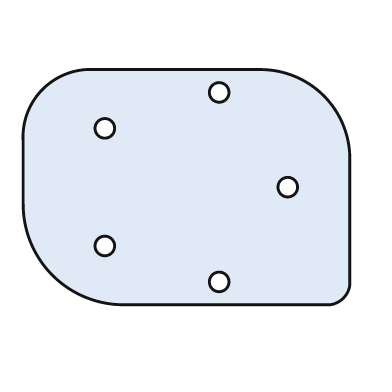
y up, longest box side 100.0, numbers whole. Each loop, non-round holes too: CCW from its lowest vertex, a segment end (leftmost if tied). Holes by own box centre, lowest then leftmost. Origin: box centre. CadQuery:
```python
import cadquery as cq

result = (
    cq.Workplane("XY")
    .moveTo(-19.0, -36.0)
    .lineTo(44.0, -36.0)
    .threePointArc((48.0, -34.0), (50.0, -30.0))
    .lineTo(50.0, 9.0)
    .threePointArc((42.0, 28.0), (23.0, 36.0))
    .lineTo(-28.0, 36.0)
    .threePointArc((-44.0, 30.0), (-50.0, 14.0))
    .lineTo(-50.0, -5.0)
    .threePointArc((-41.0, -27.0), (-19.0, -36.0))
    .close()
    .moveTo(10.0, -29.0)
    .circle(3.0)
    .moveTo(-25.0, -18.0)
    .circle(3.0)
    .moveTo(31.0, 0.0)
    .circle(3.0)
    .moveTo(-25.0, 18.0)
    .circle(3.0)
    .moveTo(10.0, 29.0)
    .circle(3.0)
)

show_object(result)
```